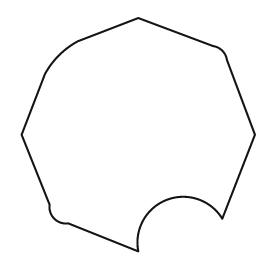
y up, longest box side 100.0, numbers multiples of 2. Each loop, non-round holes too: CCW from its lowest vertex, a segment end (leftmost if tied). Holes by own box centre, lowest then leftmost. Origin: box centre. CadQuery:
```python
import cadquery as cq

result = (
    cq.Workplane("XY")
    .moveTo(0.0, -50.0)
    .threePointArc((12.0, -28.0), (36.0, -36.0))
    .lineTo(50.0, 0.0)
    .lineTo(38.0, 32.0)
    .threePointArc((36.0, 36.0), (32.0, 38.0))
    .lineTo(0.0, 50.0)
    .lineTo(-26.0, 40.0)
    .threePointArc((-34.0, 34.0), (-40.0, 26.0))
    .lineTo(-50.0, 0.0)
    .lineTo(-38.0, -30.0)
    .threePointArc((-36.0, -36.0), (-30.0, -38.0))
    .close()
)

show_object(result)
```